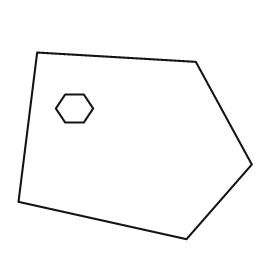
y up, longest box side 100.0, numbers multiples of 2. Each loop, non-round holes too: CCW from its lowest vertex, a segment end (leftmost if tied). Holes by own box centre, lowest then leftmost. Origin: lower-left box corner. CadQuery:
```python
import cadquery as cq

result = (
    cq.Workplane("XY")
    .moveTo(72.0, 0.0)
    .lineTo(100.0, 32.0)
    .lineTo(76.0, 76.0)
    .lineTo(8.0, 80.0)
    .lineTo(0.0, 16.0)
    .close()
    .moveTo(20.0, 50.0)
    .lineTo(28.0, 50.0)
    .lineTo(32.0, 56.0)
    .lineTo(28.0, 62.0)
    .lineTo(20.0, 62.0)
    .lineTo(16.0, 56.0)
    .close()
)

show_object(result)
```